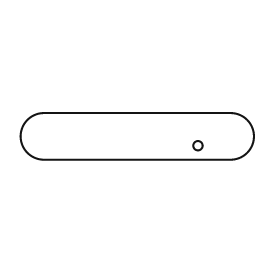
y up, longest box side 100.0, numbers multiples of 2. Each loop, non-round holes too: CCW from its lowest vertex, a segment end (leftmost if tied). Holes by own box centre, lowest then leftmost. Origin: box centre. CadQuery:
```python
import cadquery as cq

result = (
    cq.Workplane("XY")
    .moveTo(-40.0, -10.0)
    .lineTo(40.0, -10.0)
    .threePointArc((50.0, 0.0), (40.0, 10.0))
    .lineTo(-40.0, 10.0)
    .threePointArc((-50.0, 0.0), (-40.0, -10.0))
    .close()
    .moveTo(26.0, -4.0)
    .circle(2.0)
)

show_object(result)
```